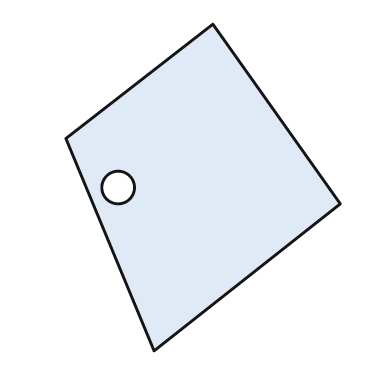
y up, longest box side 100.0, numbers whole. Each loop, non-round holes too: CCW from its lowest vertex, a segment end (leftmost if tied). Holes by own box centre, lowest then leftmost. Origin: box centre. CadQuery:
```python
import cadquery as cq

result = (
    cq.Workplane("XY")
    .moveTo(-15.0, -50.0)
    .lineTo(42.0, -5.0)
    .lineTo(3.0, 50.0)
    .lineTo(-42.0, 15.0)
    .close()
    .moveTo(-26.0, 0.0)
    .circle(5.0)
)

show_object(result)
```